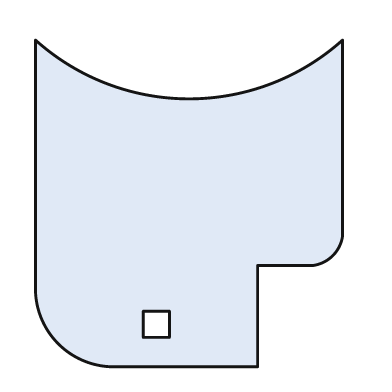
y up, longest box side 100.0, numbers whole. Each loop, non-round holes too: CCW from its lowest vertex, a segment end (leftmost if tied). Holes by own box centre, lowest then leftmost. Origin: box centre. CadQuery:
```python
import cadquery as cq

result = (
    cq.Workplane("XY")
    .moveTo(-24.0, -50.0)
    .lineTo(21.0, -50.0)
    .lineTo(21.0, -19.0)
    .lineTo(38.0, -19.0)
    .threePointArc((44.0, -16.0), (47.0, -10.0))
    .lineTo(47.0, 50.0)
    .threePointArc((0.0, 32.0), (-47.0, 50.0))
    .lineTo(-47.0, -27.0)
    .threePointArc((-40.0, -43.0), (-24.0, -50.0))
    .close()
    .moveTo(-14.0, -41.0)
    .lineTo(-6.0, -41.0)
    .lineTo(-6.0, -33.0)
    .lineTo(-14.0, -33.0)
    .close()
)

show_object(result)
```